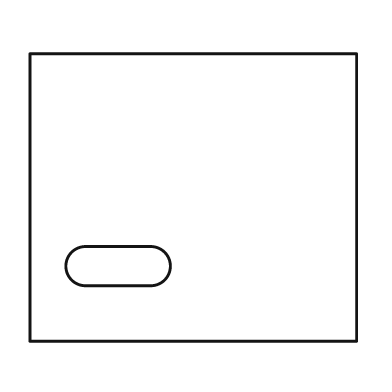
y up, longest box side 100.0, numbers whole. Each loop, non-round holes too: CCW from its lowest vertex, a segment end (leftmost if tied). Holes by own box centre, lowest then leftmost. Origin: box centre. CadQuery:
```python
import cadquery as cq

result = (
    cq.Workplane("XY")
    .moveTo(-50.0, -44.0)
    .lineTo(50.0, -44.0)
    .lineTo(50.0, 44.0)
    .lineTo(-50.0, 44.0)
    .close()
    .moveTo(-33.0, -27.0)
    .lineTo(-13.0, -27.0)
    .threePointArc((-7.0, -21.0), (-13.0, -15.0))
    .lineTo(-33.0, -15.0)
    .threePointArc((-39.0, -21.0), (-33.0, -27.0))
    .close()
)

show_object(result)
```